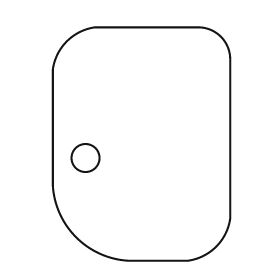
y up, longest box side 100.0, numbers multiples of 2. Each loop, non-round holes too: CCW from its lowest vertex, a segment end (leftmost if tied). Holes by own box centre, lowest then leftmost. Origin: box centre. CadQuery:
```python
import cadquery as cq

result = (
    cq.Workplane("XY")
    .moveTo(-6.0, -50.0)
    .lineTo(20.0, -50.0)
    .threePointArc((32.0, -44.0), (38.0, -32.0))
    .lineTo(38.0, 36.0)
    .threePointArc((34.0, 46.0), (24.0, 50.0))
    .lineTo(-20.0, 50.0)
    .threePointArc((-32.0, 44.0), (-38.0, 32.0))
    .lineTo(-38.0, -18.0)
    .threePointArc((-28.0, -40.0), (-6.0, -50.0))
    .close()
    .moveTo(-24.0, -6.0)
    .circle(6.0)
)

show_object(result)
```